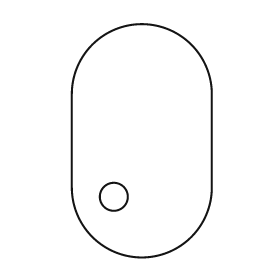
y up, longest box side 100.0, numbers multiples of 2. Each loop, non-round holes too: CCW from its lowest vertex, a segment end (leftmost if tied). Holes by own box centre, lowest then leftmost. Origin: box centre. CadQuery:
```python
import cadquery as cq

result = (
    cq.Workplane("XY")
    .moveTo(-30.0, -20.0)
    .threePointArc((0.0, -50.0), (30.0, -20.0))
    .lineTo(30.0, 20.0)
    .threePointArc((0.0, 50.0), (-30.0, 20.0))
    .close()
    .moveTo(-12.0, -24.0)
    .circle(6.0)
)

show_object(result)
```